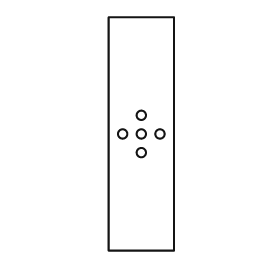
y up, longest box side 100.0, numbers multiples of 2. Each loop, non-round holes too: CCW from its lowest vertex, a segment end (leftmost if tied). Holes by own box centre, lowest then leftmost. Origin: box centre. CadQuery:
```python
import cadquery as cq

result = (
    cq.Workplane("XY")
    .moveTo(-14.0, -50.0)
    .lineTo(14.0, -50.0)
    .lineTo(14.0, 50.0)
    .lineTo(-14.0, 50.0)
    .close()
    .moveTo(0.0, -8.0)
    .circle(2.0)
    .moveTo(-8.0, 0.0)
    .circle(2.0)
    .moveTo(0.0, 0.0)
    .circle(2.0)
    .moveTo(8.0, 0.0)
    .circle(2.0)
    .moveTo(0.0, 8.0)
    .circle(2.0)
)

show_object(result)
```